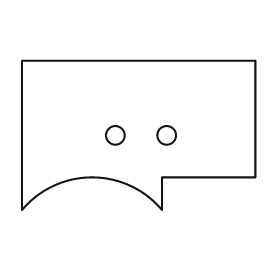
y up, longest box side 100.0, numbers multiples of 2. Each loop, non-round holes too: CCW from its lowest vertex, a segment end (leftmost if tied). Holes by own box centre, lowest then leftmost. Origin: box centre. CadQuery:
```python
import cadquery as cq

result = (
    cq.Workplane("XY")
    .moveTo(-50.0, -32.0)
    .threePointArc((-20.0, -18.0), (10.0, -32.0))
    .lineTo(10.0, -18.0)
    .lineTo(50.0, -18.0)
    .lineTo(50.0, 32.0)
    .lineTo(-50.0, 32.0)
    .close()
    .moveTo(-10.0, 0.0)
    .circle(4.0)
    .moveTo(12.0, 0.0)
    .circle(4.0)
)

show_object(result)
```